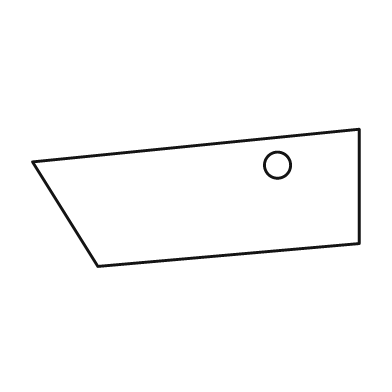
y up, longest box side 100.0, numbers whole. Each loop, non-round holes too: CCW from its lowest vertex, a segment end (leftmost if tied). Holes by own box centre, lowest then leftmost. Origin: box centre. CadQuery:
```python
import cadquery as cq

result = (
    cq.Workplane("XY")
    .moveTo(-30.0, -21.0)
    .lineTo(50.0, -14.0)
    .lineTo(50.0, 21.0)
    .lineTo(-50.0, 11.0)
    .close()
    .moveTo(25.0, 10.0)
    .circle(4.0)
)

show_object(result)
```